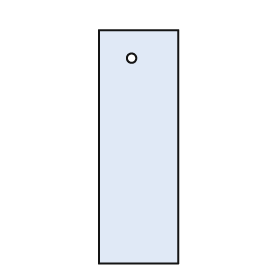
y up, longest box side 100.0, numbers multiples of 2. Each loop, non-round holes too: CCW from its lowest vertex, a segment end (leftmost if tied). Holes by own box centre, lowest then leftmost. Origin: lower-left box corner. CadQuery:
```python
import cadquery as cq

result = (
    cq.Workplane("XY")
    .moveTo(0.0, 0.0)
    .lineTo(34.0, 0.0)
    .lineTo(34.0, 100.0)
    .lineTo(0.0, 100.0)
    .close()
    .moveTo(14.0, 88.0)
    .circle(2.0)
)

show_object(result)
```